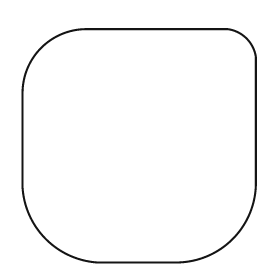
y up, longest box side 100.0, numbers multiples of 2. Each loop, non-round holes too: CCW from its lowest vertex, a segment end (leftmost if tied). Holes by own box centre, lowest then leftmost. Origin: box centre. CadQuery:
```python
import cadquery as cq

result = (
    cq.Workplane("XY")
    .moveTo(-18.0, -50.0)
    .lineTo(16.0, -50.0)
    .threePointArc((40.0, -40.0), (50.0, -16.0))
    .lineTo(50.0, 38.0)
    .threePointArc((46.0, 46.0), (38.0, 50.0))
    .lineTo(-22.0, 50.0)
    .threePointArc((-42.0, 42.0), (-50.0, 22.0))
    .lineTo(-50.0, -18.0)
    .threePointArc((-40.0, -40.0), (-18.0, -50.0))
    .close()
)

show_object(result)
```